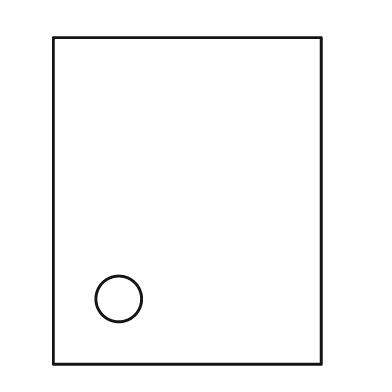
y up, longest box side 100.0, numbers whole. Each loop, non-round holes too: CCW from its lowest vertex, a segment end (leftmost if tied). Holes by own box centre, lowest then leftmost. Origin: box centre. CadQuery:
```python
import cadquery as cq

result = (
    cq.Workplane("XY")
    .moveTo(-41.0, -50.0)
    .lineTo(41.0, -50.0)
    .lineTo(41.0, 50.0)
    .lineTo(-41.0, 50.0)
    .close()
    .moveTo(-21.0, -30.0)
    .circle(7.0)
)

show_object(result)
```